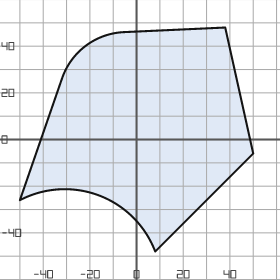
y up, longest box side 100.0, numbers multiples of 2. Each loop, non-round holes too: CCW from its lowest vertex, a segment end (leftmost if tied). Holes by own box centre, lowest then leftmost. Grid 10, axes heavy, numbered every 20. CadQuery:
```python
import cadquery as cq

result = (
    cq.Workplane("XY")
    .moveTo(8.0, -48.0)
    .lineTo(50.0, -6.0)
    .lineTo(38.0, 48.0)
    .lineTo(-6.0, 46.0)
    .threePointArc((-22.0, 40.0), (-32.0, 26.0))
    .lineTo(-50.0, -26.0)
    .threePointArc((-16.0, -24.0), (8.0, -48.0))
    .close()
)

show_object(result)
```